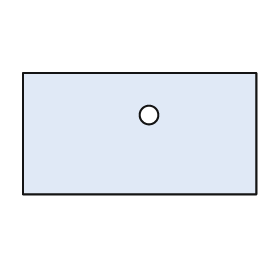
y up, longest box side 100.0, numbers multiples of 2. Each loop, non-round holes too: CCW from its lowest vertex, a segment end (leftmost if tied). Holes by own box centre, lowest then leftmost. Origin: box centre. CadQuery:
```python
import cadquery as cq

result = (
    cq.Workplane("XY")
    .moveTo(-50.0, -26.0)
    .lineTo(50.0, -26.0)
    .lineTo(50.0, 26.0)
    .lineTo(-50.0, 26.0)
    .close()
    .moveTo(4.0, 8.0)
    .circle(4.0)
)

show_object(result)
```